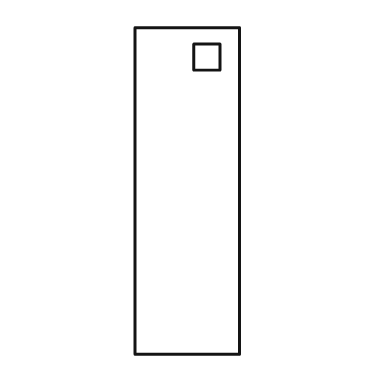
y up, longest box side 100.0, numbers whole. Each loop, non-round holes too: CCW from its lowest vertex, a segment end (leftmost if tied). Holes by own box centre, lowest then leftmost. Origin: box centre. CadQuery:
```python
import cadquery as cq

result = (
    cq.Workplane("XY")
    .moveTo(-16.0, -50.0)
    .lineTo(16.0, -50.0)
    .lineTo(16.0, 50.0)
    .lineTo(-16.0, 50.0)
    .close()
    .moveTo(2.0, 37.0)
    .lineTo(10.0, 37.0)
    .lineTo(10.0, 45.0)
    .lineTo(2.0, 45.0)
    .close()
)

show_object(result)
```